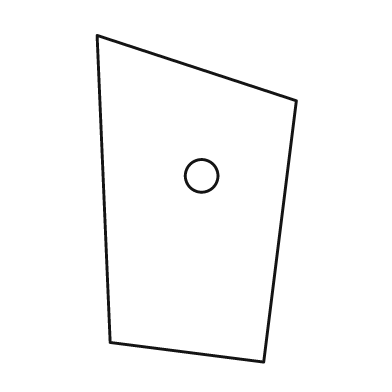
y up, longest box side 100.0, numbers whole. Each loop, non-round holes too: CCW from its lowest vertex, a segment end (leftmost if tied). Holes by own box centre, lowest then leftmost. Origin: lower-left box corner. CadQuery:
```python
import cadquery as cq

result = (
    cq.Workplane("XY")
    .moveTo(51.0, 0.0)
    .lineTo(61.0, 80.0)
    .lineTo(0.0, 100.0)
    .lineTo(4.0, 6.0)
    .close()
    .moveTo(32.0, 57.0)
    .circle(5.0)
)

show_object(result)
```